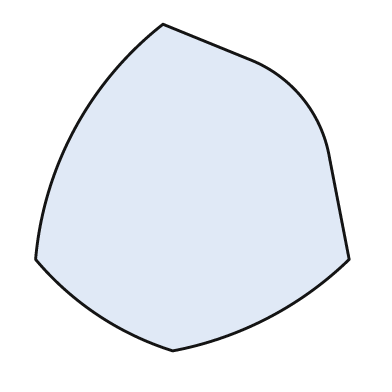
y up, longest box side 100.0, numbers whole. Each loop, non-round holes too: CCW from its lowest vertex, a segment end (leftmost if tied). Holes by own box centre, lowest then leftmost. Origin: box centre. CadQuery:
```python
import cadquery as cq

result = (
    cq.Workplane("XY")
    .moveTo(-6.0, -50.0)
    .threePointArc((23.0, -40.0), (48.0, -22.0))
    .lineTo(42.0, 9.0)
    .threePointArc((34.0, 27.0), (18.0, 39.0))
    .lineTo(-9.0, 50.0)
    .threePointArc((-36.0, 18.0), (-48.0, -22.0))
    .threePointArc((-29.0, -39.0), (-6.0, -50.0))
    .close()
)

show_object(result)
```